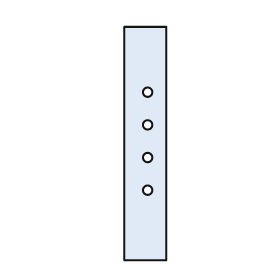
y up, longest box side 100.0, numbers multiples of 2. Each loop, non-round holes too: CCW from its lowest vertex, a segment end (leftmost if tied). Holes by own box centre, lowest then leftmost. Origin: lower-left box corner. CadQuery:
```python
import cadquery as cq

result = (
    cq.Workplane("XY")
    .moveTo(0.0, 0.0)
    .lineTo(18.0, 0.0)
    .lineTo(18.0, 100.0)
    .lineTo(0.0, 100.0)
    .close()
    .moveTo(10.0, 30.0)
    .circle(2.0)
    .moveTo(10.0, 44.0)
    .circle(2.0)
    .moveTo(10.0, 58.0)
    .circle(2.0)
    .moveTo(10.0, 72.0)
    .circle(2.0)
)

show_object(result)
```